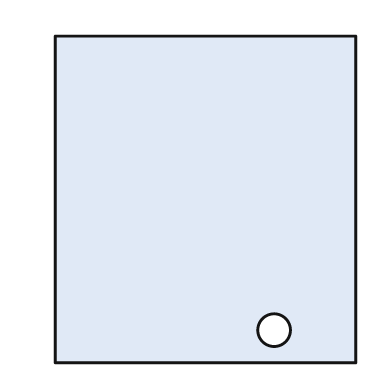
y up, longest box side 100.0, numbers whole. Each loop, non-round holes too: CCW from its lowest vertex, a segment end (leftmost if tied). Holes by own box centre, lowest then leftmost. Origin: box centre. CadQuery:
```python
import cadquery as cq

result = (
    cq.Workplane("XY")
    .moveTo(-46.0, -50.0)
    .lineTo(46.0, -50.0)
    .lineTo(46.0, 50.0)
    .lineTo(-46.0, 50.0)
    .close()
    .moveTo(21.0, -40.0)
    .circle(5.0)
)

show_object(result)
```